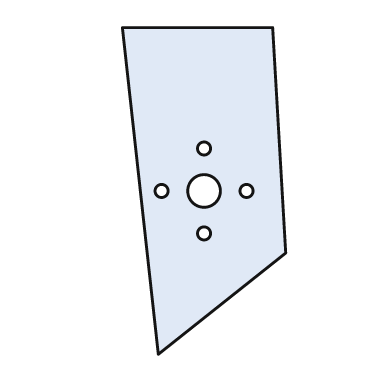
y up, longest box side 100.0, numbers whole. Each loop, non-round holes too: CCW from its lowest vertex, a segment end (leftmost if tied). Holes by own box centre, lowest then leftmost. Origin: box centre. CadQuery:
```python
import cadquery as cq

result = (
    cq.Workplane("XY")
    .moveTo(-14.0, -50.0)
    .lineTo(25.0, -19.0)
    .lineTo(21.0, 50.0)
    .lineTo(-25.0, 50.0)
    .close()
    .moveTo(0.0, -13.0)
    .circle(2.0)
    .moveTo(-13.0, 0.0)
    .circle(2.0)
    .moveTo(0.0, 0.0)
    .circle(5.0)
    .moveTo(13.0, 0.0)
    .circle(2.0)
    .moveTo(0.0, 13.0)
    .circle(2.0)
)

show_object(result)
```